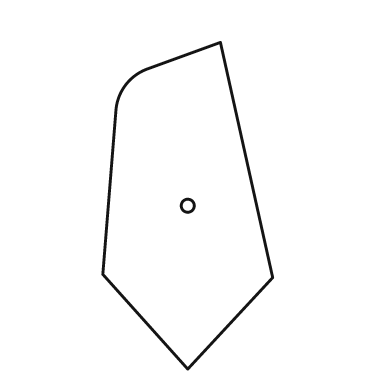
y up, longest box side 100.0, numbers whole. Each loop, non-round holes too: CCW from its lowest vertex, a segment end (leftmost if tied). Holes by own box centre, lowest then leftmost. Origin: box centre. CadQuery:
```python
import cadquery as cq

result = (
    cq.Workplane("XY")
    .moveTo(0.0, -50.0)
    .lineTo(26.0, -22.0)
    .lineTo(10.0, 50.0)
    .lineTo(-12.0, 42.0)
    .threePointArc((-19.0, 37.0), (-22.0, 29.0))
    .lineTo(-26.0, -21.0)
    .close()
    .moveTo(0.0, 0.0)
    .circle(2.0)
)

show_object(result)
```